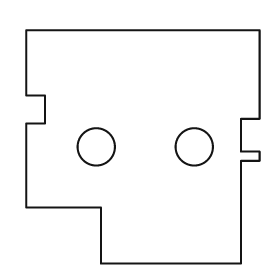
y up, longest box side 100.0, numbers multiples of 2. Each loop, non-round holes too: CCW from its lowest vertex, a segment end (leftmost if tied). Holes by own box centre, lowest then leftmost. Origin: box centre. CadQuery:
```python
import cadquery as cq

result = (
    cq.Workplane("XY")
    .moveTo(-18.0, -50.0)
    .lineTo(42.0, -50.0)
    .lineTo(42.0, -6.0)
    .lineTo(50.0, -6.0)
    .lineTo(50.0, -2.0)
    .lineTo(42.0, -2.0)
    .lineTo(42.0, 12.0)
    .lineTo(50.0, 12.0)
    .lineTo(50.0, 50.0)
    .lineTo(-50.0, 50.0)
    .lineTo(-50.0, 22.0)
    .lineTo(-42.0, 22.0)
    .lineTo(-42.0, 10.0)
    .lineTo(-50.0, 10.0)
    .lineTo(-50.0, -26.0)
    .lineTo(-18.0, -26.0)
    .close()
    .moveTo(-20.0, 0.0)
    .circle(8.0)
    .moveTo(22.0, 0.0)
    .circle(8.0)
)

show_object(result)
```